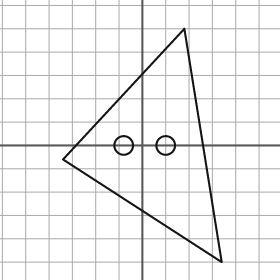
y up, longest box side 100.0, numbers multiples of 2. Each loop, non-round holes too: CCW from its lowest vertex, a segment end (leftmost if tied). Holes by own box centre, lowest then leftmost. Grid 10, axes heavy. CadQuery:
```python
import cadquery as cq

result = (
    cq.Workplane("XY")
    .moveTo(34.0, -50.0)
    .lineTo(18.0, 50.0)
    .lineTo(-34.0, -6.0)
    .close()
    .moveTo(-8.0, 0.0)
    .circle(4.0)
    .moveTo(10.0, 0.0)
    .circle(4.0)
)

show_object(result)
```